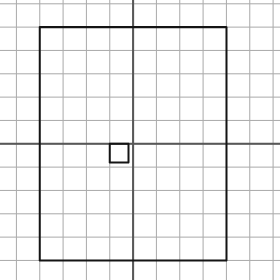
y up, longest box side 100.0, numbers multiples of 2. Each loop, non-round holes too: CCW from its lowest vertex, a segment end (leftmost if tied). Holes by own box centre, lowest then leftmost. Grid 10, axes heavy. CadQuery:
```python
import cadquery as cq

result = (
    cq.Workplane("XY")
    .moveTo(-40.0, -50.0)
    .lineTo(40.0, -50.0)
    .lineTo(40.0, 50.0)
    .lineTo(-40.0, 50.0)
    .close()
    .moveTo(-10.0, -8.0)
    .lineTo(-2.0, -8.0)
    .lineTo(-2.0, 0.0)
    .lineTo(-10.0, 0.0)
    .close()
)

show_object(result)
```